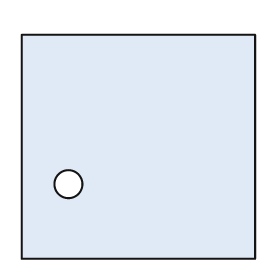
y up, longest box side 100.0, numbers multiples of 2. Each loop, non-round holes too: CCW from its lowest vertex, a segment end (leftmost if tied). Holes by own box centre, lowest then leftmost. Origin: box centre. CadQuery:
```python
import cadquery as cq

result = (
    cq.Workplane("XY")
    .moveTo(-50.0, -48.0)
    .lineTo(50.0, -48.0)
    .lineTo(50.0, 48.0)
    .lineTo(-50.0, 48.0)
    .close()
    .moveTo(-30.0, -16.0)
    .circle(6.0)
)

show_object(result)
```